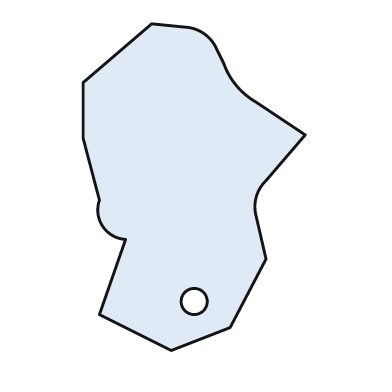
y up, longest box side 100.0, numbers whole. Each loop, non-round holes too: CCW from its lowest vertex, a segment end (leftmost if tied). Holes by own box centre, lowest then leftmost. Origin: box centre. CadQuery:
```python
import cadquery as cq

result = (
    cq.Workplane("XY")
    .moveTo(-7.0, -50.0)
    .lineTo(11.0, -43.0)
    .lineTo(22.0, -22.0)
    .lineTo(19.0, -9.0)
    .threePointArc((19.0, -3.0), (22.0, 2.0))
    .lineTo(34.0, 16.0)
    .lineTo(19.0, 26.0)
    .threePointArc((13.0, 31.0), (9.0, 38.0))
    .lineTo(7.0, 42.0)
    .threePointArc((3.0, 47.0), (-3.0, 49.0))
    .lineTo(-13.0, 50.0)
    .lineTo(-34.0, 32.0)
    .lineTo(-34.0, 15.0)
    .lineTo(-29.0, -4.0)
    .threePointArc((-28.0, -12.0), (-21.0, -16.0))
    .lineTo(-29.0, -39.0)
    .close()
    .moveTo(0.0, -35.0)
    .circle(4.0)
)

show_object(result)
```